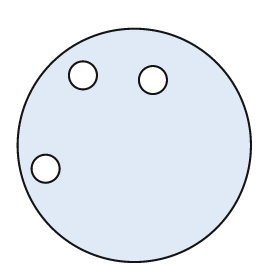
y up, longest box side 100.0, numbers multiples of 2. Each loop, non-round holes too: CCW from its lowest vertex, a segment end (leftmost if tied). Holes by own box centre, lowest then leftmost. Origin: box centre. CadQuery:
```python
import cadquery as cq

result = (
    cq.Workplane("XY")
    .moveTo(0.0, 0.0)
    .circle(50.0)
    .moveTo(-38.0, -10.0)
    .circle(6.0)
    .moveTo(8.0, 28.0)
    .circle(6.0)
    .moveTo(-22.0, 30.0)
    .circle(6.0)
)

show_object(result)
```